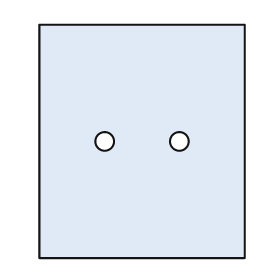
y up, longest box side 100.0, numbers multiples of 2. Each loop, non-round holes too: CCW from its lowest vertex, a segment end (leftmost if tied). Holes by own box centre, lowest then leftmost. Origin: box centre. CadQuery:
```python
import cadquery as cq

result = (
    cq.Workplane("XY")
    .moveTo(-44.0, -50.0)
    .lineTo(44.0, -50.0)
    .lineTo(44.0, 50.0)
    .lineTo(-44.0, 50.0)
    .close()
    .moveTo(-16.0, 0.0)
    .circle(4.0)
    .moveTo(16.0, 0.0)
    .circle(4.0)
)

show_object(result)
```